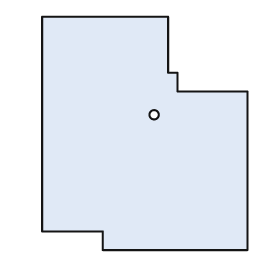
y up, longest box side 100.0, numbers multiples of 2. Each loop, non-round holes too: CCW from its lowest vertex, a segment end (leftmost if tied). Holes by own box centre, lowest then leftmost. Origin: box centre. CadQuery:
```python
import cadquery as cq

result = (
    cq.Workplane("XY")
    .moveTo(-18.0, -50.0)
    .lineTo(44.0, -50.0)
    .lineTo(44.0, 18.0)
    .lineTo(14.0, 18.0)
    .lineTo(14.0, 26.0)
    .lineTo(10.0, 26.0)
    .lineTo(10.0, 50.0)
    .lineTo(-44.0, 50.0)
    .lineTo(-44.0, -42.0)
    .lineTo(-18.0, -42.0)
    .close()
    .moveTo(4.0, 8.0)
    .circle(2.0)
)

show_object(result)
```